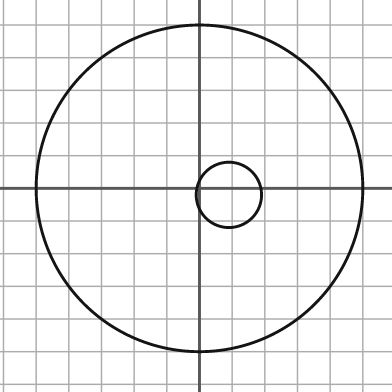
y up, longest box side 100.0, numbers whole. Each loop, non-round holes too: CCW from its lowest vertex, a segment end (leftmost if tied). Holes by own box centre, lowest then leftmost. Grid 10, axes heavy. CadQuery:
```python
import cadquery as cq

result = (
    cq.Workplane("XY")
    .moveTo(0.0, 0.0)
    .circle(50.0)
    .moveTo(9.0, -2.0)
    .circle(10.0)
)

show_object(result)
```